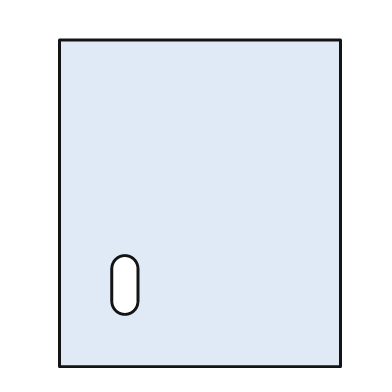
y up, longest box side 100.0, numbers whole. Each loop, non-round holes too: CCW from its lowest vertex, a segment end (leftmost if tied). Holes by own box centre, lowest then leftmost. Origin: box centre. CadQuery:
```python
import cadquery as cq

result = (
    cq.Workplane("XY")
    .moveTo(-43.0, -50.0)
    .lineTo(43.0, -50.0)
    .lineTo(43.0, 50.0)
    .lineTo(-43.0, 50.0)
    .close()
    .moveTo(-27.0, -30.0)
    .threePointArc((-23.0, -34.0), (-19.0, -30.0))
    .lineTo(-19.0, -20.0)
    .threePointArc((-23.0, -16.0), (-27.0, -20.0))
    .close()
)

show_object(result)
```